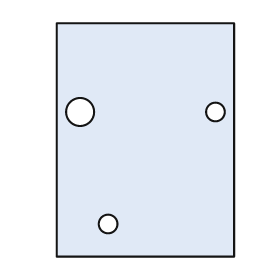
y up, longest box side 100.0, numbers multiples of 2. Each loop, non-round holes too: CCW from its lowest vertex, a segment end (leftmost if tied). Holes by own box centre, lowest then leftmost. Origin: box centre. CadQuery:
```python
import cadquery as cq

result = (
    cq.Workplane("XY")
    .moveTo(-38.0, -50.0)
    .lineTo(38.0, -50.0)
    .lineTo(38.0, 50.0)
    .lineTo(-38.0, 50.0)
    .close()
    .moveTo(-16.0, -36.0)
    .circle(4.0)
    .moveTo(-28.0, 12.0)
    .circle(6.0)
    .moveTo(30.0, 12.0)
    .circle(4.0)
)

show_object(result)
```